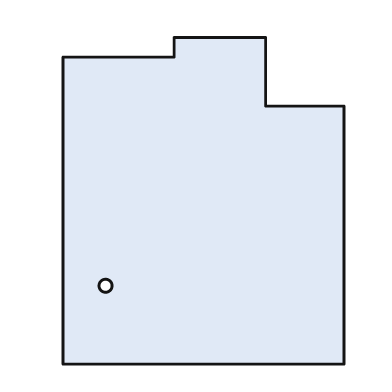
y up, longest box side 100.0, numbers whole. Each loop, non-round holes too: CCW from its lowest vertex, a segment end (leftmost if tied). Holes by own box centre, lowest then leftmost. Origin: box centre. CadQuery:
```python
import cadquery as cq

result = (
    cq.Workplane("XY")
    .moveTo(-43.0, -50.0)
    .lineTo(43.0, -50.0)
    .lineTo(43.0, 29.0)
    .lineTo(19.0, 29.0)
    .lineTo(19.0, 50.0)
    .lineTo(-9.0, 50.0)
    .lineTo(-9.0, 44.0)
    .lineTo(-43.0, 44.0)
    .close()
    .moveTo(-30.0, -26.0)
    .circle(2.0)
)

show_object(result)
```